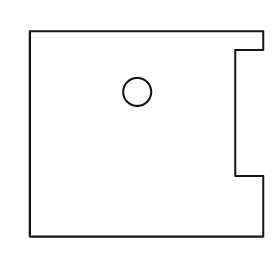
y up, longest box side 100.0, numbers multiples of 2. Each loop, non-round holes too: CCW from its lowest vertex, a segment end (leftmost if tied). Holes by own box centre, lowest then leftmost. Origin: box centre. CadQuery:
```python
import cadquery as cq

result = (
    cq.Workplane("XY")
    .moveTo(-50.0, -44.0)
    .lineTo(50.0, -44.0)
    .lineTo(50.0, -18.0)
    .lineTo(38.0, -18.0)
    .lineTo(38.0, 36.0)
    .lineTo(50.0, 36.0)
    .lineTo(50.0, 44.0)
    .lineTo(-50.0, 44.0)
    .close()
    .moveTo(-4.0, 18.0)
    .circle(6.0)
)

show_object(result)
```